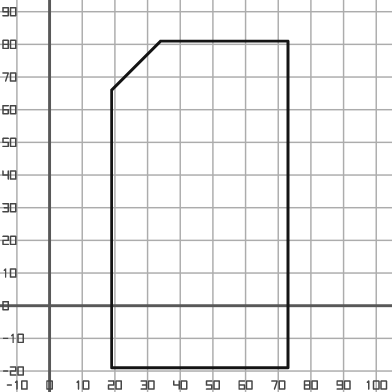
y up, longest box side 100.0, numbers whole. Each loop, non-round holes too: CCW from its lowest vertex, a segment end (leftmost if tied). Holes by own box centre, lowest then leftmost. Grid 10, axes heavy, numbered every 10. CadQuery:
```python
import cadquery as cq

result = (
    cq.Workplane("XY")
    .moveTo(19.0, -19.0)
    .lineTo(73.0, -19.0)
    .lineTo(73.0, 81.0)
    .lineTo(34.0, 81.0)
    .lineTo(19.0, 66.0)
    .close()
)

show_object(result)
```